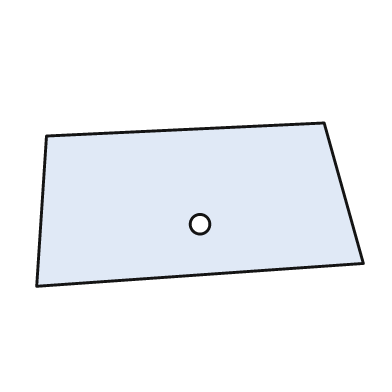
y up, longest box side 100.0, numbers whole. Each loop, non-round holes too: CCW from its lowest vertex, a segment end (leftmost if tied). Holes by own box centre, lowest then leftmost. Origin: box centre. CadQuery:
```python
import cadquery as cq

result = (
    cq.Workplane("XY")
    .moveTo(-50.0, -25.0)
    .lineTo(50.0, -18.0)
    .lineTo(38.0, 25.0)
    .lineTo(-47.0, 21.0)
    .close()
    .moveTo(0.0, -6.0)
    .circle(3.0)
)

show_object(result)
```